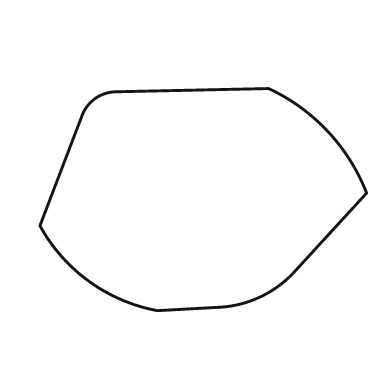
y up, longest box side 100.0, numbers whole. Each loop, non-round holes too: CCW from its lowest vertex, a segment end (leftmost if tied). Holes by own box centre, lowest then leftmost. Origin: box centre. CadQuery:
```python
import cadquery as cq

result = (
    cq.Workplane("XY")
    .moveTo(-14.0, -34.0)
    .lineTo(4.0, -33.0)
    .threePointArc((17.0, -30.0), (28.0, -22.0))
    .lineTo(50.0, 2.0)
    .threePointArc((38.0, 21.0), (20.0, 34.0))
    .lineTo(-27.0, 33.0)
    .threePointArc((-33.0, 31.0), (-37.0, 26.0))
    .lineTo(-50.0, -8.0)
    .threePointArc((-35.0, -25.0), (-14.0, -34.0))
    .close()
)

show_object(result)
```